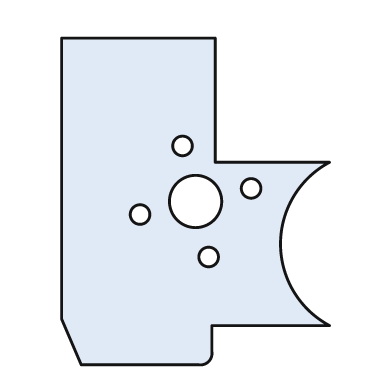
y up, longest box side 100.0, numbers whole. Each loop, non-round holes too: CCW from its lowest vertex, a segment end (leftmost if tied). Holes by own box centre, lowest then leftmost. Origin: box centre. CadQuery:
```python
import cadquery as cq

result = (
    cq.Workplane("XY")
    .moveTo(-35.0, -50.0)
    .lineTo(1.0, -50.0)
    .threePointArc((4.0, -49.0), (5.0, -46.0))
    .lineTo(5.0, -38.0)
    .lineTo(41.0, -38.0)
    .threePointArc((26.0, -13.0), (41.0, 12.0))
    .lineTo(6.0, 12.0)
    .lineTo(6.0, 50.0)
    .lineTo(-41.0, 50.0)
    .lineTo(-41.0, -36.0)
    .close()
    .moveTo(4.0, -17.0)
    .circle(3.0)
    .moveTo(-17.0, -4.0)
    .circle(3.0)
    .moveTo(0.0, 0.0)
    .circle(8.0)
    .moveTo(17.0, 4.0)
    .circle(3.0)
    .moveTo(-4.0, 17.0)
    .circle(3.0)
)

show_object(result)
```